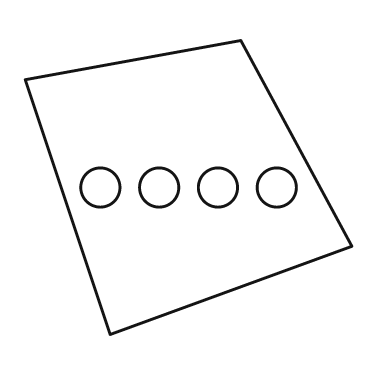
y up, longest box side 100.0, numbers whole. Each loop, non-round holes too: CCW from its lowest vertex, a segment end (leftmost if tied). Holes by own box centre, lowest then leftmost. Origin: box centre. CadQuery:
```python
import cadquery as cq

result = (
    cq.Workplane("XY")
    .moveTo(-24.0, -45.0)
    .lineTo(50.0, -18.0)
    .lineTo(16.0, 45.0)
    .lineTo(-50.0, 33.0)
    .close()
    .moveTo(-27.0, 0.0)
    .circle(6.0)
    .moveTo(-9.0, 0.0)
    .circle(6.0)
    .moveTo(9.0, 0.0)
    .circle(6.0)
    .moveTo(27.0, 0.0)
    .circle(6.0)
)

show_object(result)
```